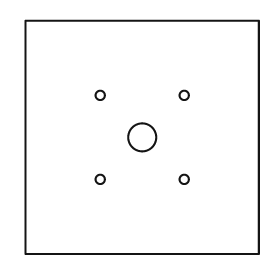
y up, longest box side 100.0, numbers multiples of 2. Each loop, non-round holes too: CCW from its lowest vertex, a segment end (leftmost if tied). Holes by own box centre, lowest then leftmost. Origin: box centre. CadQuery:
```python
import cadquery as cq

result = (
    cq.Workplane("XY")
    .moveTo(-50.0, -50.0)
    .lineTo(50.0, -50.0)
    .lineTo(50.0, 50.0)
    .lineTo(-50.0, 50.0)
    .close()
    .moveTo(-18.0, -18.0)
    .circle(2.0)
    .moveTo(18.0, -18.0)
    .circle(2.0)
    .moveTo(0.0, 0.0)
    .circle(6.0)
    .moveTo(-18.0, 18.0)
    .circle(2.0)
    .moveTo(18.0, 18.0)
    .circle(2.0)
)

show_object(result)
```